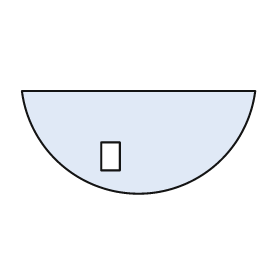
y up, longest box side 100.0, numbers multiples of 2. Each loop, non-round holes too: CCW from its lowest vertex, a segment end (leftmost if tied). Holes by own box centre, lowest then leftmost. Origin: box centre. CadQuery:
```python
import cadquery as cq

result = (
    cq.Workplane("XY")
    .moveTo(-50.0, 22.0)
    .threePointArc((0.0, -22.0), (50.0, 22.0))
    .close()
    .moveTo(-16.0, -12.0)
    .lineTo(-8.0, -12.0)
    .lineTo(-8.0, 0.0)
    .lineTo(-16.0, 0.0)
    .close()
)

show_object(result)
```